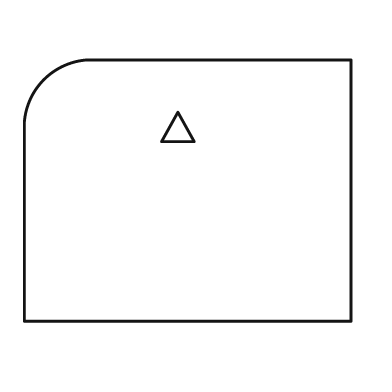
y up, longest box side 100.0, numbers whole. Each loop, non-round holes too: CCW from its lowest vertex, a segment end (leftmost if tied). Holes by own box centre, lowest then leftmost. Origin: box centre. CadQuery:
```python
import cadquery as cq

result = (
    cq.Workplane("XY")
    .moveTo(-50.0, -40.0)
    .lineTo(50.0, -40.0)
    .lineTo(50.0, 40.0)
    .lineTo(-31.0, 40.0)
    .threePointArc((-44.0, 34.0), (-50.0, 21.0))
    .close()
    .moveTo(-8.0, 15.0)
    .lineTo(2.0, 15.0)
    .lineTo(-3.0, 24.0)
    .close()
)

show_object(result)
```